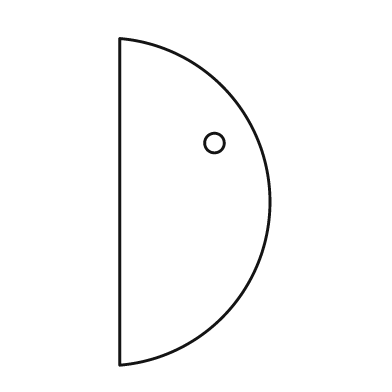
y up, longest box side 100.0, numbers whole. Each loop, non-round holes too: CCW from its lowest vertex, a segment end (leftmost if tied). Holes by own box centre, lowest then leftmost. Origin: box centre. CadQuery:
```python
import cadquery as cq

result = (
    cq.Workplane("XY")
    .moveTo(-23.0, -50.0)
    .threePointArc((23.0, 0.0), (-23.0, 50.0))
    .close()
    .moveTo(6.0, 18.0)
    .circle(3.0)
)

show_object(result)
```